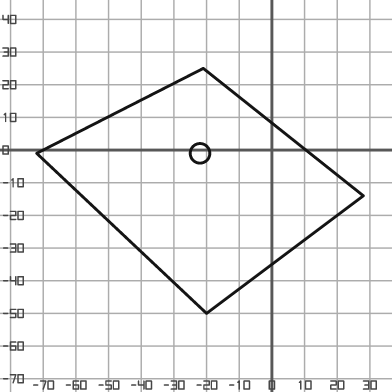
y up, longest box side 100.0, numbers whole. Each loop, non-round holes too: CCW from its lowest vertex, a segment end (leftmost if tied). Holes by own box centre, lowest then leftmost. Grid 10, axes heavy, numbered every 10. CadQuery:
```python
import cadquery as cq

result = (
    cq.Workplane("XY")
    .moveTo(-20.0, -50.0)
    .lineTo(28.0, -14.0)
    .lineTo(-21.0, 25.0)
    .lineTo(-72.0, -1.0)
    .close()
    .moveTo(-22.0, -1.0)
    .circle(3.0)
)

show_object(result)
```